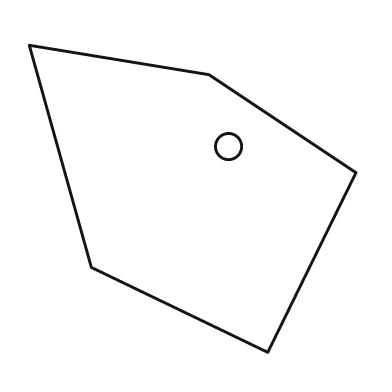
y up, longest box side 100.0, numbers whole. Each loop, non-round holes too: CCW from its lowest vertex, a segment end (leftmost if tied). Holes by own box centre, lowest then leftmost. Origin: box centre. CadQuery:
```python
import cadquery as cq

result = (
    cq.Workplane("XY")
    .moveTo(23.0, -47.0)
    .lineTo(50.0, 8.0)
    .lineTo(5.0, 38.0)
    .lineTo(-50.0, 47.0)
    .lineTo(-31.0, -21.0)
    .close()
    .moveTo(11.0, 16.0)
    .circle(4.0)
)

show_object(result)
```